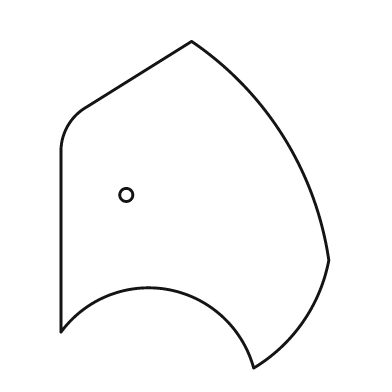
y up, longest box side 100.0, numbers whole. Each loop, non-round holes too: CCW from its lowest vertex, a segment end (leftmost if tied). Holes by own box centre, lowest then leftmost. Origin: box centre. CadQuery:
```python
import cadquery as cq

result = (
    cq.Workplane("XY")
    .moveTo(18.0, -50.0)
    .threePointArc((33.0, -36.0), (41.0, -17.0))
    .threePointArc((27.0, 21.0), (-1.0, 50.0))
    .lineTo(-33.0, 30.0)
    .threePointArc((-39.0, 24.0), (-41.0, 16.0))
    .lineTo(-41.0, -39.0)
    .threePointArc((-8.0, -26.0), (18.0, -50.0))
    .close()
    .moveTo(-21.0, 3.0)
    .circle(2.0)
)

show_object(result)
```